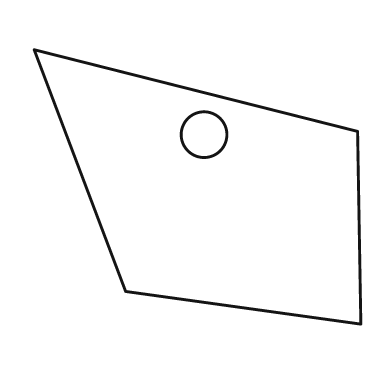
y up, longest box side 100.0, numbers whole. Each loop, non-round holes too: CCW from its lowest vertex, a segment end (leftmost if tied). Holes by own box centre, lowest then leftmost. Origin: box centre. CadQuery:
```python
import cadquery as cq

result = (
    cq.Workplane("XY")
    .moveTo(50.0, -42.0)
    .lineTo(49.0, 17.0)
    .lineTo(-50.0, 42.0)
    .lineTo(-22.0, -32.0)
    .close()
    .moveTo(2.0, 16.0)
    .circle(7.0)
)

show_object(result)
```